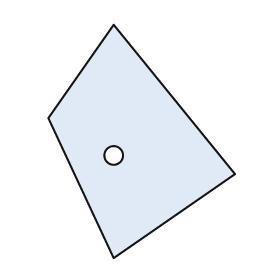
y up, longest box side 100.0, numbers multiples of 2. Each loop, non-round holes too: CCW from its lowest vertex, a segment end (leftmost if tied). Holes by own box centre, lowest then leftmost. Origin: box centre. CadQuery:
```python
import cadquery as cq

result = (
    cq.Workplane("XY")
    .moveTo(-12.0, -50.0)
    .lineTo(40.0, -14.0)
    .lineTo(-12.0, 50.0)
    .lineTo(-40.0, 10.0)
    .close()
    .moveTo(-12.0, -6.0)
    .circle(4.0)
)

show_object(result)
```